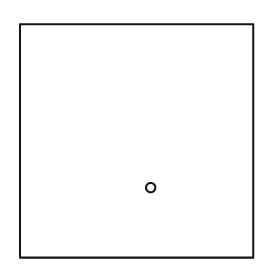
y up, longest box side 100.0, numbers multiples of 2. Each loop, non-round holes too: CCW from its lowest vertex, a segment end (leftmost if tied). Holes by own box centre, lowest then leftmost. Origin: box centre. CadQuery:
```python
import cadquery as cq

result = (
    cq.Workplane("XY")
    .moveTo(-50.0, -50.0)
    .lineTo(50.0, -50.0)
    .lineTo(50.0, 50.0)
    .lineTo(-50.0, 50.0)
    .close()
    .moveTo(6.0, -20.0)
    .circle(2.0)
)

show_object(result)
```